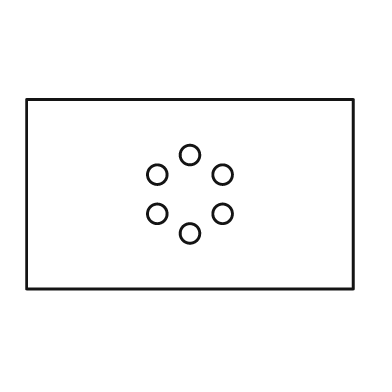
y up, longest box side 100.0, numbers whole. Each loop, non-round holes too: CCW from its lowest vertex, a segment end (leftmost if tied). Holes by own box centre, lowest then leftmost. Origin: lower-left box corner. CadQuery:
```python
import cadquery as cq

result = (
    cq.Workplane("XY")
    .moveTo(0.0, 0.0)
    .lineTo(100.0, 0.0)
    .lineTo(100.0, 58.0)
    .lineTo(0.0, 58.0)
    .close()
    .moveTo(50.0, 17.0)
    .circle(3.0)
    .moveTo(40.0, 23.0)
    .circle(3.0)
    .moveTo(60.0, 23.0)
    .circle(3.0)
    .moveTo(40.0, 35.0)
    .circle(3.0)
    .moveTo(60.0, 35.0)
    .circle(3.0)
    .moveTo(50.0, 41.0)
    .circle(3.0)
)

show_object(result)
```